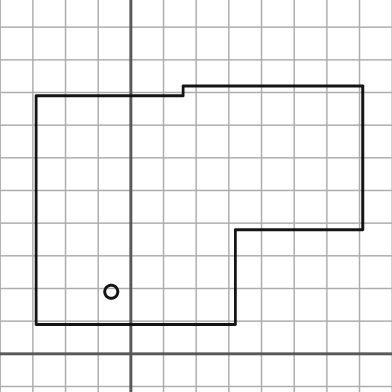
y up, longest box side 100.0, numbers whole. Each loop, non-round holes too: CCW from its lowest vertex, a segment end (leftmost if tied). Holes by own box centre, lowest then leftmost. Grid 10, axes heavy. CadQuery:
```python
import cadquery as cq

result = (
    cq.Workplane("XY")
    .moveTo(-29.0, 9.0)
    .lineTo(32.0, 9.0)
    .lineTo(32.0, 38.0)
    .lineTo(71.0, 38.0)
    .lineTo(71.0, 82.0)
    .lineTo(16.0, 82.0)
    .lineTo(16.0, 79.0)
    .lineTo(-29.0, 79.0)
    .close()
    .moveTo(-6.0, 19.0)
    .circle(2.0)
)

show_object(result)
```